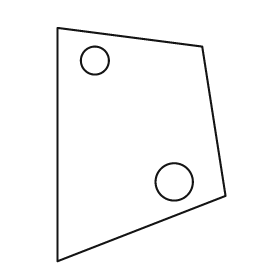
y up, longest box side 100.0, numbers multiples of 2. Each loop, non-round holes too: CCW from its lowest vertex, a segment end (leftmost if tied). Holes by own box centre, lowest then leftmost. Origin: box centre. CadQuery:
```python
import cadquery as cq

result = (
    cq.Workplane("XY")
    .moveTo(-36.0, -50.0)
    .lineTo(36.0, -22.0)
    .lineTo(26.0, 42.0)
    .lineTo(-36.0, 50.0)
    .close()
    .moveTo(14.0, -16.0)
    .circle(8.0)
    .moveTo(-20.0, 36.0)
    .circle(6.0)
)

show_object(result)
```